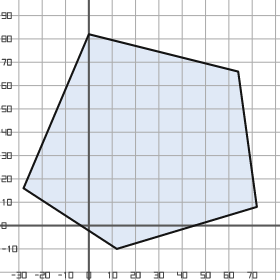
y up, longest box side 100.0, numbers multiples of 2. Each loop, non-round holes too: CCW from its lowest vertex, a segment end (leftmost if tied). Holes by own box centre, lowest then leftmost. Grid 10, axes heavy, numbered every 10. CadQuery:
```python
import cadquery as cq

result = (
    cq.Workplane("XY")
    .moveTo(12.0, -10.0)
    .lineTo(72.0, 8.0)
    .lineTo(64.0, 66.0)
    .lineTo(0.0, 82.0)
    .lineTo(-28.0, 16.0)
    .close()
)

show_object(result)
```